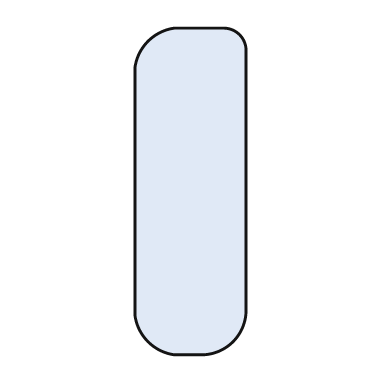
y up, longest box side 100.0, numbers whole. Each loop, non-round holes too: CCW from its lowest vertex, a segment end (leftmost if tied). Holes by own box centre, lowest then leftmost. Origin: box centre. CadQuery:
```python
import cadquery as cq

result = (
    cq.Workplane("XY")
    .moveTo(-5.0, -50.0)
    .lineTo(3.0, -50.0)
    .threePointArc((13.0, -46.0), (17.0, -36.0))
    .lineTo(17.0, 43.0)
    .threePointArc((15.0, 48.0), (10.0, 50.0))
    .lineTo(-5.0, 50.0)
    .threePointArc((-13.0, 46.0), (-17.0, 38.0))
    .lineTo(-17.0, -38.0)
    .threePointArc((-13.0, -46.0), (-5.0, -50.0))
    .close()
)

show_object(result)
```